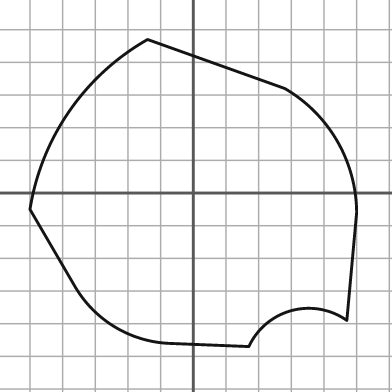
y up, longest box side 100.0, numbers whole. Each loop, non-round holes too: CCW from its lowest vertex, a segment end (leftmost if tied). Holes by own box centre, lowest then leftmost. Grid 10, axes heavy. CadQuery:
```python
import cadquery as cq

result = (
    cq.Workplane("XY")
    .moveTo(17.0, -47.0)
    .threePointArc((30.0, -36.0), (47.0, -39.0))
    .lineTo(50.0, -6.0)
    .threePointArc((44.0, 16.0), (28.0, 32.0))
    .lineTo(-14.0, 47.0)
    .threePointArc((-38.0, 25.0), (-50.0, -5.0))
    .lineTo(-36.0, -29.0)
    .threePointArc((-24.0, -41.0), (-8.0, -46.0))
    .close()
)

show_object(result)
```